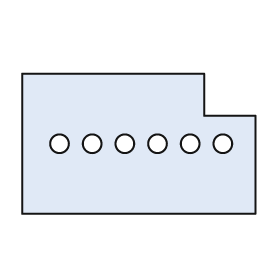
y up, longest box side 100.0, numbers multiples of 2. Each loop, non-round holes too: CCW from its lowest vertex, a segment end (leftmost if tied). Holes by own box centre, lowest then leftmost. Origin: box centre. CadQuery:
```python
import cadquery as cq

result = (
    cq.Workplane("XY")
    .moveTo(-50.0, -30.0)
    .lineTo(50.0, -30.0)
    .lineTo(50.0, 12.0)
    .lineTo(28.0, 12.0)
    .lineTo(28.0, 30.0)
    .lineTo(-50.0, 30.0)
    .close()
    .moveTo(-34.0, 0.0)
    .circle(4.0)
    .moveTo(-20.0, 0.0)
    .circle(4.0)
    .moveTo(-6.0, 0.0)
    .circle(4.0)
    .moveTo(8.0, 0.0)
    .circle(4.0)
    .moveTo(22.0, 0.0)
    .circle(4.0)
    .moveTo(36.0, 0.0)
    .circle(4.0)
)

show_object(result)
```